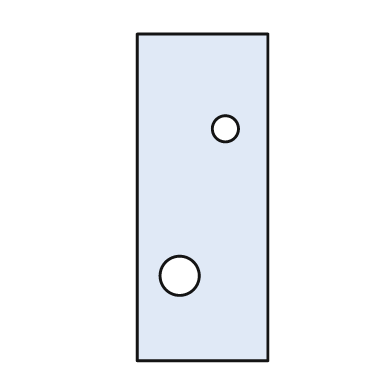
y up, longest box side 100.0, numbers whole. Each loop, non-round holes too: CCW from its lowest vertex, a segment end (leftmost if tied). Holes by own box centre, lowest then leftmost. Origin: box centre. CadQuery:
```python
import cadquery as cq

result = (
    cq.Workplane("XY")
    .moveTo(-20.0, -50.0)
    .lineTo(20.0, -50.0)
    .lineTo(20.0, 50.0)
    .lineTo(-20.0, 50.0)
    .close()
    .moveTo(-7.0, -24.0)
    .circle(6.0)
    .moveTo(7.0, 21.0)
    .circle(4.0)
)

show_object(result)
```